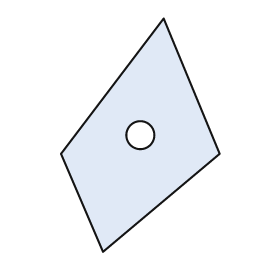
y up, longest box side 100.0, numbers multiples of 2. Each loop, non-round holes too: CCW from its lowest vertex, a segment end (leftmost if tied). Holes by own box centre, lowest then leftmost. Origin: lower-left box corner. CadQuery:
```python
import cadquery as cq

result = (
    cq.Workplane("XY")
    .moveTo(18.0, 0.0)
    .lineTo(68.0, 42.0)
    .lineTo(44.0, 100.0)
    .lineTo(0.0, 42.0)
    .close()
    .moveTo(34.0, 50.0)
    .circle(6.0)
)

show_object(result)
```